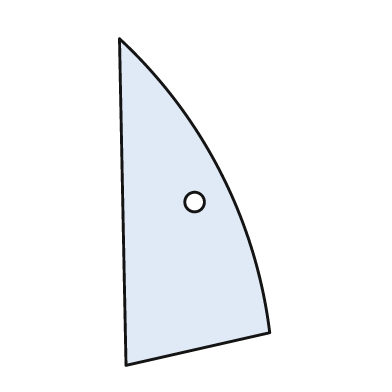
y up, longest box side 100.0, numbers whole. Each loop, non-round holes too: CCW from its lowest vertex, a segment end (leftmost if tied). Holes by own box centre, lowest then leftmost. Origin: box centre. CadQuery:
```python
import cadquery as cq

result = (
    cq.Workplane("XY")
    .moveTo(-21.0, -50.0)
    .lineTo(23.0, -40.0)
    .threePointArc((8.0, 9.0), (-23.0, 50.0))
    .close()
    .moveTo(0.0, 0.0)
    .circle(3.0)
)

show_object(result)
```